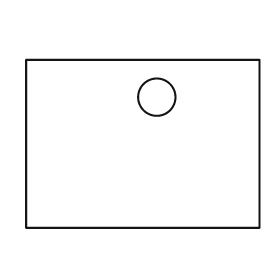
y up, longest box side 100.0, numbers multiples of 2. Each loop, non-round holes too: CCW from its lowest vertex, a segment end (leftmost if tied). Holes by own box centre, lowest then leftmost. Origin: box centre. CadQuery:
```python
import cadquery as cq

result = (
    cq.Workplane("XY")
    .moveTo(-50.0, -36.0)
    .lineTo(50.0, -36.0)
    .lineTo(50.0, 36.0)
    .lineTo(-50.0, 36.0)
    .close()
    .moveTo(6.0, 20.0)
    .circle(8.0)
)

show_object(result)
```